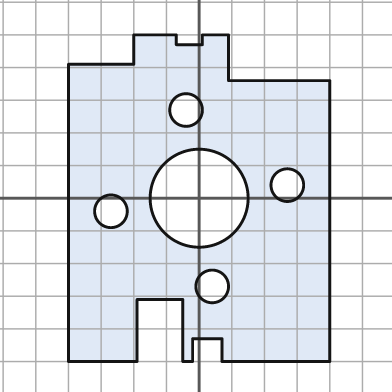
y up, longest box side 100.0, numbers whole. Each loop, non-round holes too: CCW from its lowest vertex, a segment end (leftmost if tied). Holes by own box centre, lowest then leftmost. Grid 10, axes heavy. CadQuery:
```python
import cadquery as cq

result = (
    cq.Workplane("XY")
    .moveTo(-40.0, -50.0)
    .lineTo(-19.0, -50.0)
    .lineTo(-19.0, -31.0)
    .lineTo(-5.0, -31.0)
    .lineTo(-5.0, -50.0)
    .lineTo(-2.0, -50.0)
    .lineTo(-2.0, -43.0)
    .lineTo(7.0, -43.0)
    .lineTo(7.0, -50.0)
    .lineTo(40.0, -50.0)
    .lineTo(40.0, 36.0)
    .lineTo(9.0, 36.0)
    .lineTo(9.0, 50.0)
    .lineTo(1.0, 50.0)
    .lineTo(1.0, 47.0)
    .lineTo(-7.0, 47.0)
    .lineTo(-7.0, 50.0)
    .lineTo(-20.0, 50.0)
    .lineTo(-20.0, 41.0)
    .lineTo(-40.0, 41.0)
    .close()
    .moveTo(4.0, -27.0)
    .circle(5.0)
    .moveTo(-27.0, -4.0)
    .circle(5.0)
    .moveTo(0.0, 0.0)
    .circle(15.0)
    .moveTo(27.0, 4.0)
    .circle(5.0)
    .moveTo(-4.0, 27.0)
    .circle(5.0)
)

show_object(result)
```